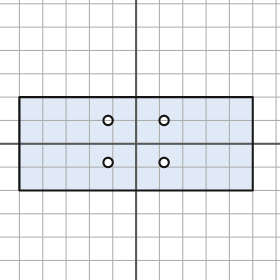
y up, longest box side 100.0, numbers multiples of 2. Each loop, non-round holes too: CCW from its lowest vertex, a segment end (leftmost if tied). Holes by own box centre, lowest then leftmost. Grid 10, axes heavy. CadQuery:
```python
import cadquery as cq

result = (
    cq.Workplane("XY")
    .moveTo(-50.0, -20.0)
    .lineTo(50.0, -20.0)
    .lineTo(50.0, 20.0)
    .lineTo(-50.0, 20.0)
    .close()
    .moveTo(-12.0, -8.0)
    .circle(2.0)
    .moveTo(12.0, -8.0)
    .circle(2.0)
    .moveTo(-12.0, 10.0)
    .circle(2.0)
    .moveTo(12.0, 10.0)
    .circle(2.0)
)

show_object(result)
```